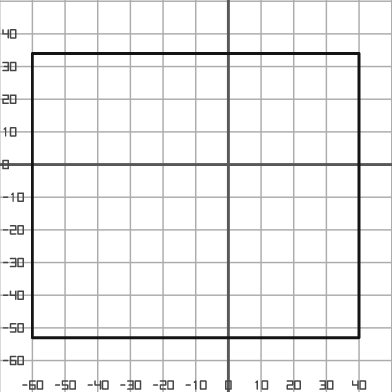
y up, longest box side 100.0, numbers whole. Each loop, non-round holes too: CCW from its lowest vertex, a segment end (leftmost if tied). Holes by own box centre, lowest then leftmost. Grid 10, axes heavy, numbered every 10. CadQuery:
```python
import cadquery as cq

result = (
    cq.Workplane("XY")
    .moveTo(-60.0, -53.0)
    .lineTo(40.0, -53.0)
    .lineTo(40.0, 34.0)
    .lineTo(-60.0, 34.0)
    .close()
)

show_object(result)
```